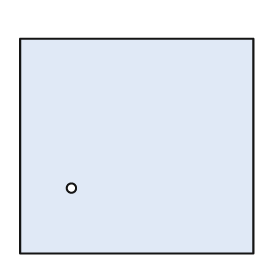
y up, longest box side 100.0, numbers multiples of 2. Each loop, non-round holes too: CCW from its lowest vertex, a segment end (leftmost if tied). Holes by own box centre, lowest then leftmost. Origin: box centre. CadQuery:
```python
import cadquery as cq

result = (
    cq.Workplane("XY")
    .moveTo(-50.0, -46.0)
    .lineTo(50.0, -46.0)
    .lineTo(50.0, 46.0)
    .lineTo(-50.0, 46.0)
    .close()
    .moveTo(-28.0, -18.0)
    .circle(2.0)
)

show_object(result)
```